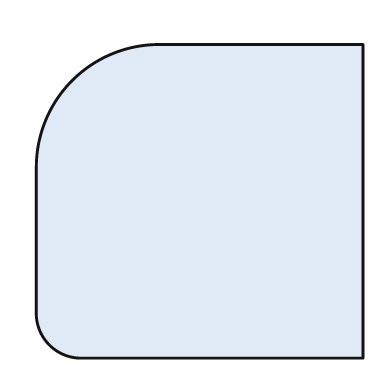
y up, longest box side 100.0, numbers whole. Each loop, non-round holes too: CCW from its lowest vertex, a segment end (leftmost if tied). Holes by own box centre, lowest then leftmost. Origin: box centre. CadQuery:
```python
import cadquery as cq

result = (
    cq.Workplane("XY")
    .moveTo(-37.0, -48.0)
    .lineTo(50.0, -48.0)
    .lineTo(50.0, 48.0)
    .lineTo(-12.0, 48.0)
    .threePointArc((-39.0, 37.0), (-50.0, 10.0))
    .lineTo(-50.0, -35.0)
    .threePointArc((-46.0, -44.0), (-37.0, -48.0))
    .close()
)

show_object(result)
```